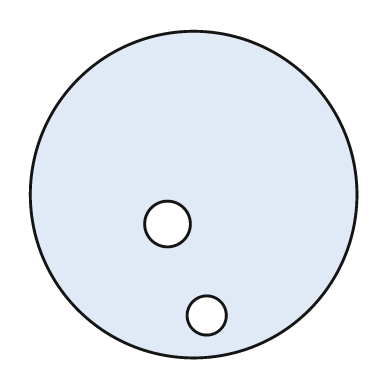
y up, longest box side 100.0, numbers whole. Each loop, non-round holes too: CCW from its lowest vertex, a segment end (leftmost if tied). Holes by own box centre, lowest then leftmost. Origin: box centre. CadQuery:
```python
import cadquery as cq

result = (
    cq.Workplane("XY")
    .moveTo(0.0, 0.0)
    .circle(50.0)
    .moveTo(4.0, -37.0)
    .circle(6.0)
    .moveTo(-8.0, -9.0)
    .circle(7.0)
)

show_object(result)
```